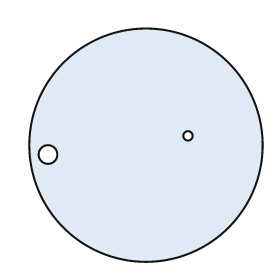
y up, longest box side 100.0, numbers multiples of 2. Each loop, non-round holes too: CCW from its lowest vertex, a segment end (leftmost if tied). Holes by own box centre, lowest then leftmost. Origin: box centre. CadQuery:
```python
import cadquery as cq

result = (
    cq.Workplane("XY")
    .moveTo(0.0, 0.0)
    .circle(50.0)
    .moveTo(-42.0, -4.0)
    .circle(4.0)
    .moveTo(18.0, 4.0)
    .circle(2.0)
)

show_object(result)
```